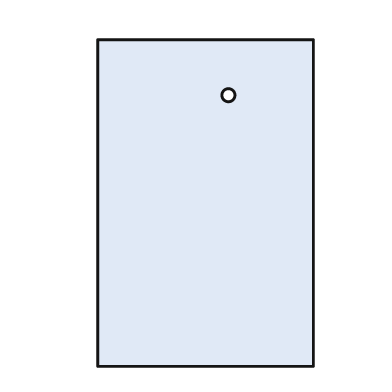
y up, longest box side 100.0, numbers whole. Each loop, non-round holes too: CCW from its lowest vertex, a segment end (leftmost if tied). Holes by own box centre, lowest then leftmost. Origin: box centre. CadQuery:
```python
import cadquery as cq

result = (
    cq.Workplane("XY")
    .moveTo(-33.0, -50.0)
    .lineTo(33.0, -50.0)
    .lineTo(33.0, 50.0)
    .lineTo(-33.0, 50.0)
    .close()
    .moveTo(7.0, 33.0)
    .circle(2.0)
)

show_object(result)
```